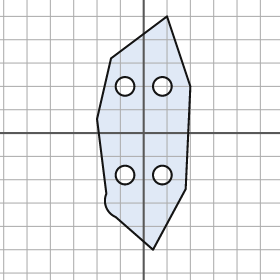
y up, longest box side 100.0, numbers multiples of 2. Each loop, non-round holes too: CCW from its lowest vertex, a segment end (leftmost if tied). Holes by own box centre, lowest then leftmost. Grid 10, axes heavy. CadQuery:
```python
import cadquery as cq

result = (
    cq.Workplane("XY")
    .moveTo(4.0, -50.0)
    .lineTo(18.0, -24.0)
    .lineTo(20.0, 20.0)
    .lineTo(10.0, 50.0)
    .lineTo(-14.0, 32.0)
    .lineTo(-20.0, 6.0)
    .lineTo(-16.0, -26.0)
    .threePointArc((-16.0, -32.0), (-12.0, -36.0))
    .close()
    .moveTo(-8.0, -18.0)
    .circle(4.0)
    .moveTo(8.0, -18.0)
    .circle(4.0)
    .moveTo(-8.0, 20.0)
    .circle(4.0)
    .moveTo(8.0, 20.0)
    .circle(4.0)
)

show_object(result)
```